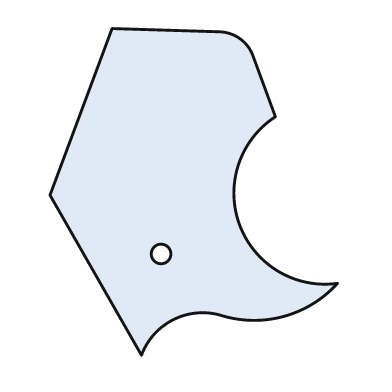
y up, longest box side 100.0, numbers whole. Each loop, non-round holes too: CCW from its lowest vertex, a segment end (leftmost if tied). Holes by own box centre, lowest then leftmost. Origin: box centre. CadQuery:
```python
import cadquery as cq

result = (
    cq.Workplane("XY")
    .moveTo(-16.0, -50.0)
    .threePointArc((-6.0, -39.0), (9.0, -38.0))
    .threePointArc((28.0, -38.0), (44.0, -28.0))
    .threePointArc((14.0, -10.0), (25.0, 23.0))
    .lineTo(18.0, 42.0)
    .threePointArc((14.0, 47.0), (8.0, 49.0))
    .lineTo(-25.0, 50.0)
    .lineTo(-44.0, -1.0)
    .close()
    .moveTo(-10.0, -19.0)
    .circle(3.0)
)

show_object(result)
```